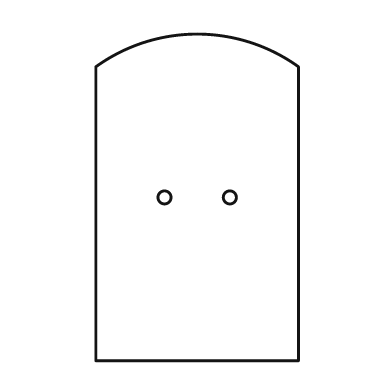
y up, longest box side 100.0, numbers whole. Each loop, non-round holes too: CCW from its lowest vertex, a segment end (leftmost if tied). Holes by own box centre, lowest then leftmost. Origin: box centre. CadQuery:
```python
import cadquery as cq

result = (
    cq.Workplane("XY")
    .moveTo(-31.0, -50.0)
    .lineTo(31.0, -50.0)
    .lineTo(31.0, 40.0)
    .threePointArc((0.0, 50.0), (-31.0, 40.0))
    .close()
    .moveTo(-10.0, 0.0)
    .circle(2.0)
    .moveTo(10.0, 0.0)
    .circle(2.0)
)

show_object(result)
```